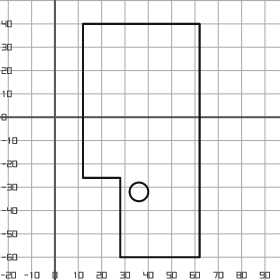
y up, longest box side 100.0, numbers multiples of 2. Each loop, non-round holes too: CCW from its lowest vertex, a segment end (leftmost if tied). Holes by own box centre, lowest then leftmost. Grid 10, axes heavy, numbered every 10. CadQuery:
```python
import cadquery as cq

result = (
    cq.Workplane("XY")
    .moveTo(28.0, -60.0)
    .lineTo(62.0, -60.0)
    .lineTo(62.0, 40.0)
    .lineTo(12.0, 40.0)
    .lineTo(12.0, -26.0)
    .lineTo(28.0, -26.0)
    .close()
    .moveTo(36.0, -32.0)
    .circle(4.0)
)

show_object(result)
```